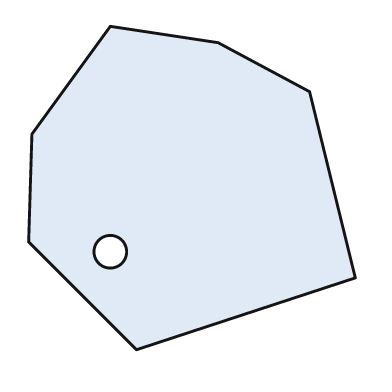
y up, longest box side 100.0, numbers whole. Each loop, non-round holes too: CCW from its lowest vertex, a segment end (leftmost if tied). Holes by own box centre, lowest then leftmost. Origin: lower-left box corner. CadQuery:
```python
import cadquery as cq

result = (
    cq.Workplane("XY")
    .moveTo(33.0, 0.0)
    .lineTo(100.0, 22.0)
    .lineTo(86.0, 79.0)
    .lineTo(58.0, 94.0)
    .lineTo(25.0, 99.0)
    .lineTo(1.0, 66.0)
    .lineTo(0.0, 33.0)
    .close()
    .moveTo(25.0, 30.0)
    .circle(5.0)
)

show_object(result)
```